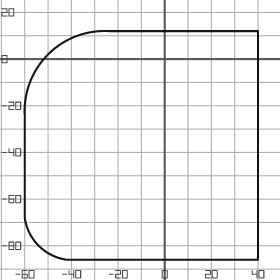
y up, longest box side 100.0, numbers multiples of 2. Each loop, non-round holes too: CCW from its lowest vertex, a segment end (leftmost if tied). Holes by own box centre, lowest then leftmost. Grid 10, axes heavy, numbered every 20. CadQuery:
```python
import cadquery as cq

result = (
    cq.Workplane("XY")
    .moveTo(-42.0, -86.0)
    .lineTo(40.0, -86.0)
    .lineTo(40.0, 12.0)
    .lineTo(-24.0, 12.0)
    .threePointArc((-50.0, 2.0), (-60.0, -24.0))
    .lineTo(-60.0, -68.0)
    .threePointArc((-54.0, -80.0), (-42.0, -86.0))
    .close()
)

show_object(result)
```